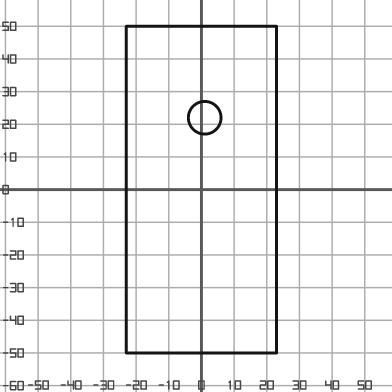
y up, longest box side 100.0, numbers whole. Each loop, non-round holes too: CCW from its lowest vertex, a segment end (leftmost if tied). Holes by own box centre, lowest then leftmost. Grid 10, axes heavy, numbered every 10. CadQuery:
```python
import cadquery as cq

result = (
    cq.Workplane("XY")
    .moveTo(-23.0, -50.0)
    .lineTo(23.0, -50.0)
    .lineTo(23.0, 50.0)
    .lineTo(-23.0, 50.0)
    .close()
    .moveTo(1.0, 22.0)
    .circle(5.0)
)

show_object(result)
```